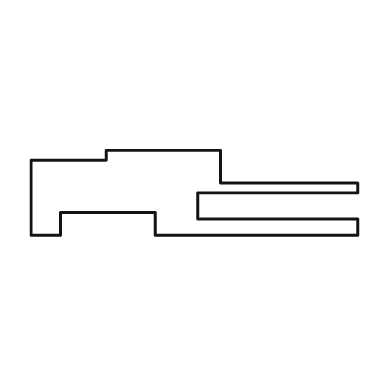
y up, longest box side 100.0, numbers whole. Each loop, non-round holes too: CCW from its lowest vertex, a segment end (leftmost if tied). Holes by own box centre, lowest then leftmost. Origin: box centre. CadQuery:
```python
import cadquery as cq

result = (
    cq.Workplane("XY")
    .moveTo(-50.0, -13.0)
    .lineTo(-41.0, -13.0)
    .lineTo(-41.0, -6.0)
    .lineTo(-12.0, -6.0)
    .lineTo(-12.0, -13.0)
    .lineTo(50.0, -13.0)
    .lineTo(50.0, -8.0)
    .lineTo(1.0, -8.0)
    .lineTo(1.0, 0.0)
    .lineTo(50.0, 0.0)
    .lineTo(50.0, 3.0)
    .lineTo(8.0, 3.0)
    .lineTo(8.0, 13.0)
    .lineTo(-27.0, 13.0)
    .lineTo(-27.0, 10.0)
    .lineTo(-50.0, 10.0)
    .close()
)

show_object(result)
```